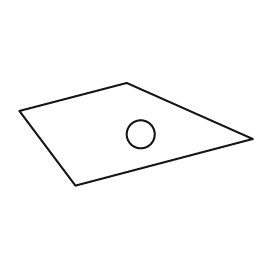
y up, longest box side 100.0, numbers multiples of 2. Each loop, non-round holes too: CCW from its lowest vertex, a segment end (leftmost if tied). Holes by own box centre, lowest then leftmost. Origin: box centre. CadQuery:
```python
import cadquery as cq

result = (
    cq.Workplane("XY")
    .moveTo(-26.0, -22.0)
    .lineTo(50.0, -2.0)
    .lineTo(-4.0, 22.0)
    .lineTo(-50.0, 10.0)
    .close()
    .moveTo(2.0, 0.0)
    .circle(6.0)
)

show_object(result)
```